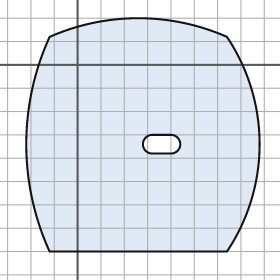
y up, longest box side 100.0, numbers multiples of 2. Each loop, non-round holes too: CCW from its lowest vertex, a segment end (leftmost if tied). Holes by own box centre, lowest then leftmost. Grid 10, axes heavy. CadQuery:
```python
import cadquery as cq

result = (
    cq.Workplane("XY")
    .moveTo(-12.0, -80.0)
    .lineTo(64.0, -80.0)
    .threePointArc((78.0, -34.0), (64.0, 12.0))
    .threePointArc((26.0, 20.0), (-12.0, 12.0))
    .threePointArc((-22.0, -34.0), (-12.0, -80.0))
    .close()
    .moveTo(32.0, -38.0)
    .lineTo(40.0, -38.0)
    .threePointArc((44.0, -34.0), (40.0, -30.0))
    .lineTo(32.0, -30.0)
    .threePointArc((28.0, -34.0), (32.0, -38.0))
    .close()
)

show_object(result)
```